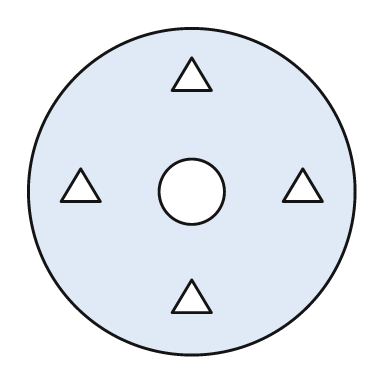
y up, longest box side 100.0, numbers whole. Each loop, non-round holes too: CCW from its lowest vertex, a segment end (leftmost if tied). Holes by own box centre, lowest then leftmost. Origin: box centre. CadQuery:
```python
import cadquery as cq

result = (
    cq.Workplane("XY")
    .moveTo(0.0, 0.0)
    .circle(50.0)
    .moveTo(-6.0, -37.0)
    .lineTo(6.0, -37.0)
    .lineTo(0.0, -27.0)
    .close()
    .moveTo(0.0, 0.0)
    .circle(10.0)
    .moveTo(-40.0, -3.0)
    .lineTo(-28.0, -3.0)
    .lineTo(-34.0, 7.0)
    .close()
    .moveTo(28.0, -3.0)
    .lineTo(40.0, -3.0)
    .lineTo(34.0, 7.0)
    .close()
    .moveTo(-6.0, 31.0)
    .lineTo(6.0, 31.0)
    .lineTo(0.0, 41.0)
    .close()
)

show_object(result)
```